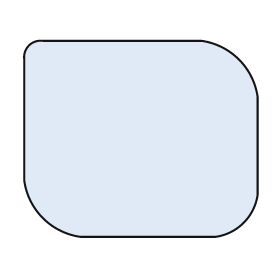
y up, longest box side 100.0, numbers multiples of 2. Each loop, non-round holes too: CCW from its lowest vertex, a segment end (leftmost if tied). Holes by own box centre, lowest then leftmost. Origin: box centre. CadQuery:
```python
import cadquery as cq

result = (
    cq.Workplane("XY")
    .moveTo(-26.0, -42.0)
    .lineTo(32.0, -42.0)
    .threePointArc((44.0, -36.0), (50.0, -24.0))
    .lineTo(50.0, 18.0)
    .threePointArc((42.0, 34.0), (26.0, 42.0))
    .lineTo(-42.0, 42.0)
    .threePointArc((-48.0, 40.0), (-50.0, 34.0))
    .lineTo(-50.0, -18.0)
    .threePointArc((-42.0, -34.0), (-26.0, -42.0))
    .close()
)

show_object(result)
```